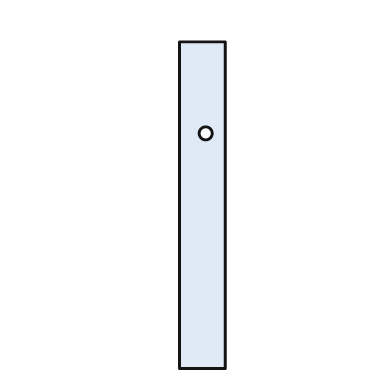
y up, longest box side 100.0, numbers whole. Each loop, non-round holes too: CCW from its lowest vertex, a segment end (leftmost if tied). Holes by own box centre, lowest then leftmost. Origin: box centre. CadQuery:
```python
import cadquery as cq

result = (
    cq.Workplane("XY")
    .moveTo(-7.0, -50.0)
    .lineTo(7.0, -50.0)
    .lineTo(7.0, 50.0)
    .lineTo(-7.0, 50.0)
    .close()
    .moveTo(1.0, 22.0)
    .circle(2.0)
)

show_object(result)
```